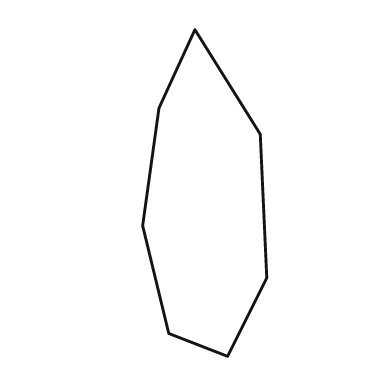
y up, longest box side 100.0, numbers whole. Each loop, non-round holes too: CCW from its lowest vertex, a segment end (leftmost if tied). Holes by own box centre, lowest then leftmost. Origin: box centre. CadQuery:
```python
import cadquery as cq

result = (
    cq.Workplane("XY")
    .moveTo(7.0, -50.0)
    .lineTo(19.0, -26.0)
    .lineTo(17.0, 18.0)
    .lineTo(-3.0, 50.0)
    .lineTo(-14.0, 26.0)
    .lineTo(-19.0, -10.0)
    .lineTo(-11.0, -43.0)
    .close()
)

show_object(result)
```